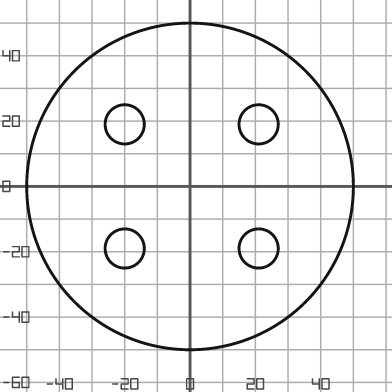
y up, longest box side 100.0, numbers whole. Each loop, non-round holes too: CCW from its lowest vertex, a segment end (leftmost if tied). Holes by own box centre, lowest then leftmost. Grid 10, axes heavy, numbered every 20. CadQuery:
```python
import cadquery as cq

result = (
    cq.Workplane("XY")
    .moveTo(0.0, 0.0)
    .circle(50.0)
    .moveTo(-20.0, -19.0)
    .circle(6.0)
    .moveTo(21.0, -19.0)
    .circle(6.0)
    .moveTo(-20.0, 19.0)
    .circle(6.0)
    .moveTo(21.0, 19.0)
    .circle(6.0)
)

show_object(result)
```